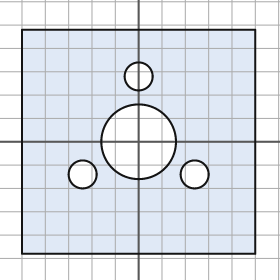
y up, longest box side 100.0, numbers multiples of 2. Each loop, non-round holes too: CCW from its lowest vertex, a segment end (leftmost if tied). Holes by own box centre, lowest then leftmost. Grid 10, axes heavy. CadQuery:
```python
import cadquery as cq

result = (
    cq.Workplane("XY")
    .moveTo(-50.0, -48.0)
    .lineTo(50.0, -48.0)
    .lineTo(50.0, 48.0)
    .lineTo(-50.0, 48.0)
    .close()
    .moveTo(-24.0, -14.0)
    .circle(6.0)
    .moveTo(24.0, -14.0)
    .circle(6.0)
    .moveTo(0.0, 0.0)
    .circle(16.0)
    .moveTo(0.0, 28.0)
    .circle(6.0)
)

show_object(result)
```